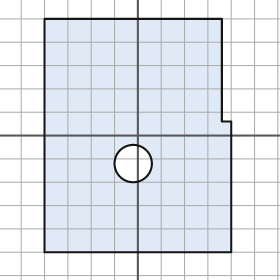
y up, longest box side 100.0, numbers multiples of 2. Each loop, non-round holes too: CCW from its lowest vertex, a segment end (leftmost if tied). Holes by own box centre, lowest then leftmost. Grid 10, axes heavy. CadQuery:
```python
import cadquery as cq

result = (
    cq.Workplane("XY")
    .moveTo(-40.0, -50.0)
    .lineTo(40.0, -50.0)
    .lineTo(40.0, 6.0)
    .lineTo(36.0, 6.0)
    .lineTo(36.0, 50.0)
    .lineTo(-40.0, 50.0)
    .close()
    .moveTo(-2.0, -12.0)
    .circle(8.0)
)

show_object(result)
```